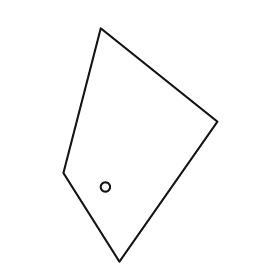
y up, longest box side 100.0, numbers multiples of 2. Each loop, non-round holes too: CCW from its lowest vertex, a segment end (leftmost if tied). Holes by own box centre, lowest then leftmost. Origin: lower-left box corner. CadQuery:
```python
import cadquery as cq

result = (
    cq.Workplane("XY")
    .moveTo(24.0, 0.0)
    .lineTo(66.0, 60.0)
    .lineTo(16.0, 100.0)
    .lineTo(0.0, 38.0)
    .close()
    .moveTo(18.0, 32.0)
    .circle(2.0)
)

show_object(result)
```